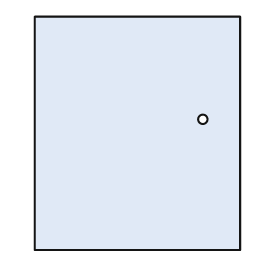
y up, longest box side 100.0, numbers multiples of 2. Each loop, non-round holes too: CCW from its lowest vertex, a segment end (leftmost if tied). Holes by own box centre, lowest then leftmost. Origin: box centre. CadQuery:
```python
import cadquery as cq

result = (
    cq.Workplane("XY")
    .moveTo(-44.0, -50.0)
    .lineTo(44.0, -50.0)
    .lineTo(44.0, 50.0)
    .lineTo(-44.0, 50.0)
    .close()
    .moveTo(28.0, 6.0)
    .circle(2.0)
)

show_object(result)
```